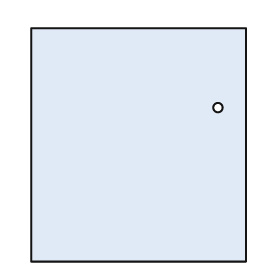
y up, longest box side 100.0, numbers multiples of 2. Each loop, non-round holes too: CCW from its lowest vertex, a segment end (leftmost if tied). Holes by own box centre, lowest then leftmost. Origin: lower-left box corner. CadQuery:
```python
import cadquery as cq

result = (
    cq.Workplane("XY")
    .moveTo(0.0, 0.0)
    .lineTo(92.0, 0.0)
    .lineTo(92.0, 100.0)
    .lineTo(0.0, 100.0)
    .close()
    .moveTo(80.0, 66.0)
    .circle(2.0)
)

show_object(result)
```